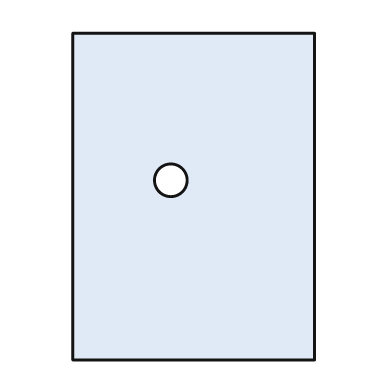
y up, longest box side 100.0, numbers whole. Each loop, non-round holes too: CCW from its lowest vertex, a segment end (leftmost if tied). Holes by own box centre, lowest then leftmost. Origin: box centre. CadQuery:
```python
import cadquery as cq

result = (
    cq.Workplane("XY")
    .moveTo(-37.0, -50.0)
    .lineTo(37.0, -50.0)
    .lineTo(37.0, 50.0)
    .lineTo(-37.0, 50.0)
    .close()
    .moveTo(-7.0, 5.0)
    .circle(5.0)
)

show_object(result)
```